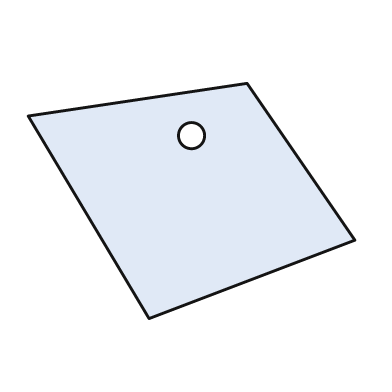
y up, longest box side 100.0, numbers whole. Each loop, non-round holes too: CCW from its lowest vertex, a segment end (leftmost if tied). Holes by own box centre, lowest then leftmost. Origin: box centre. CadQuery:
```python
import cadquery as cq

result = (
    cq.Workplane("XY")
    .moveTo(-13.0, -36.0)
    .lineTo(50.0, -12.0)
    .lineTo(17.0, 36.0)
    .lineTo(-50.0, 26.0)
    .close()
    .moveTo(0.0, 20.0)
    .circle(4.0)
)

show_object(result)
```